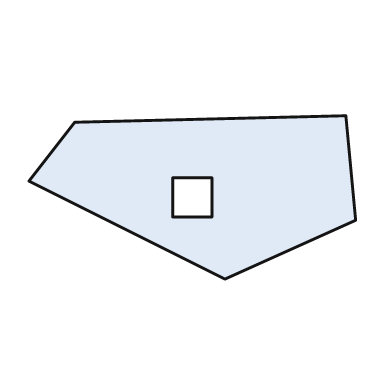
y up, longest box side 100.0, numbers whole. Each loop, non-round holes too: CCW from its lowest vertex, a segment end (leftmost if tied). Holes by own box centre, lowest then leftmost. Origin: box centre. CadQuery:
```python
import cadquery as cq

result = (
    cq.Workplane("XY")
    .moveTo(10.0, -25.0)
    .lineTo(50.0, -7.0)
    .lineTo(47.0, 25.0)
    .lineTo(-36.0, 23.0)
    .lineTo(-50.0, 5.0)
    .close()
    .moveTo(-6.0, -6.0)
    .lineTo(6.0, -6.0)
    .lineTo(6.0, 6.0)
    .lineTo(-6.0, 6.0)
    .close()
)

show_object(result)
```